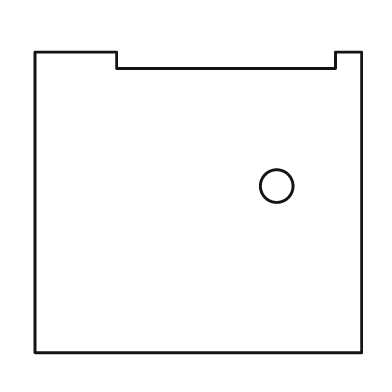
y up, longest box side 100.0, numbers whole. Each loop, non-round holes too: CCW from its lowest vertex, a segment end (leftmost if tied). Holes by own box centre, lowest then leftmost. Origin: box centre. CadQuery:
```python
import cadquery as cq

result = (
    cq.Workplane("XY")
    .moveTo(-50.0, -46.0)
    .lineTo(50.0, -46.0)
    .lineTo(50.0, 46.0)
    .lineTo(42.0, 46.0)
    .lineTo(42.0, 41.0)
    .lineTo(-25.0, 41.0)
    .lineTo(-25.0, 46.0)
    .lineTo(-50.0, 46.0)
    .close()
    .moveTo(24.0, 5.0)
    .circle(5.0)
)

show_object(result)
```